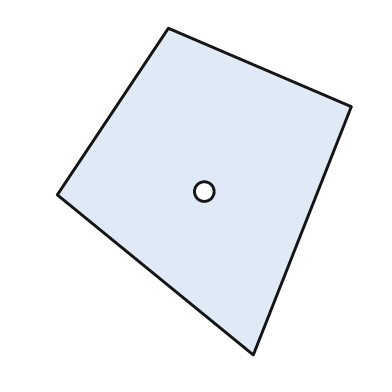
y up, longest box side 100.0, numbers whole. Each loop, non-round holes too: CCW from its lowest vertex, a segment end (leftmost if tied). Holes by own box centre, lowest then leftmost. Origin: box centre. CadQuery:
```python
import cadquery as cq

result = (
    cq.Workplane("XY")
    .moveTo(15.0, -50.0)
    .lineTo(45.0, 26.0)
    .lineTo(-11.0, 50.0)
    .lineTo(-45.0, -1.0)
    .close()
    .moveTo(0.0, 0.0)
    .circle(3.0)
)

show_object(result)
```